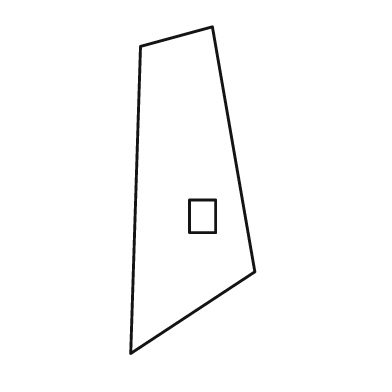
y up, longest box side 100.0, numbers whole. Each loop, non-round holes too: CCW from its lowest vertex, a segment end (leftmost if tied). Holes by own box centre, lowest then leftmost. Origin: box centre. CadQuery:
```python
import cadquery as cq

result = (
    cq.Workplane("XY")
    .moveTo(-19.0, -50.0)
    .lineTo(19.0, -25.0)
    .lineTo(6.0, 50.0)
    .lineTo(-16.0, 44.0)
    .close()
    .moveTo(-1.0, -13.0)
    .lineTo(7.0, -13.0)
    .lineTo(7.0, -3.0)
    .lineTo(-1.0, -3.0)
    .close()
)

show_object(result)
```